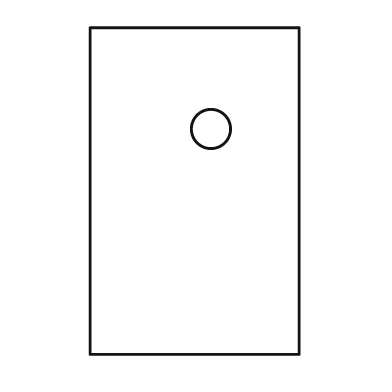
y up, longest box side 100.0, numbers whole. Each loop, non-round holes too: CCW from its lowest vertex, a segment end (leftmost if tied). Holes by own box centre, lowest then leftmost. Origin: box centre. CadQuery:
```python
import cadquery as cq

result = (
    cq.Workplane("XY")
    .moveTo(-32.0, -50.0)
    .lineTo(32.0, -50.0)
    .lineTo(32.0, 50.0)
    .lineTo(-32.0, 50.0)
    .close()
    .moveTo(5.0, 19.0)
    .circle(6.0)
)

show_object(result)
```